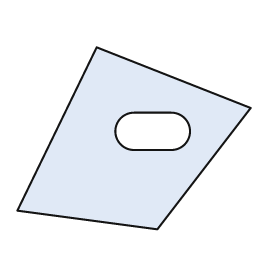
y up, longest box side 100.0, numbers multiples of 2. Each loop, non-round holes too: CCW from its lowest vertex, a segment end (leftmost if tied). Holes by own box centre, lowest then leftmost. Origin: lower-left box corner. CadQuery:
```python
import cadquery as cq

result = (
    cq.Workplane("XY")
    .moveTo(60.0, 0.0)
    .lineTo(100.0, 52.0)
    .lineTo(34.0, 78.0)
    .lineTo(0.0, 8.0)
    .close()
    .moveTo(50.0, 34.0)
    .lineTo(66.0, 34.0)
    .threePointArc((74.0, 42.0), (66.0, 50.0))
    .lineTo(50.0, 50.0)
    .threePointArc((42.0, 42.0), (50.0, 34.0))
    .close()
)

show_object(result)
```